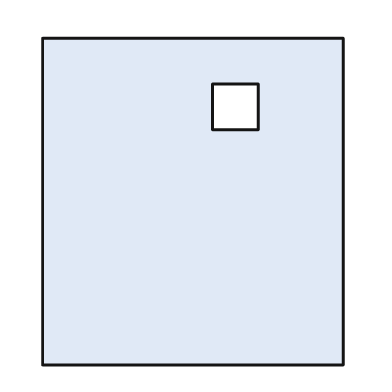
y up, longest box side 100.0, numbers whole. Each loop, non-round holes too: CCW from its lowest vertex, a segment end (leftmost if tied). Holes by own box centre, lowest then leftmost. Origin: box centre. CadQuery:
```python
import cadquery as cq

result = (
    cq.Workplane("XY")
    .moveTo(-46.0, -50.0)
    .lineTo(46.0, -50.0)
    .lineTo(46.0, 50.0)
    .lineTo(-46.0, 50.0)
    .close()
    .moveTo(6.0, 22.0)
    .lineTo(20.0, 22.0)
    .lineTo(20.0, 36.0)
    .lineTo(6.0, 36.0)
    .close()
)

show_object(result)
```